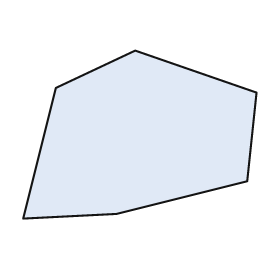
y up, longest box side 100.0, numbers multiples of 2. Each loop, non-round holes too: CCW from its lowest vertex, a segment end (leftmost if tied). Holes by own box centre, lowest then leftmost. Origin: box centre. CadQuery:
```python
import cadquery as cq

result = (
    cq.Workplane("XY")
    .moveTo(-50.0, -36.0)
    .lineTo(-10.0, -34.0)
    .lineTo(46.0, -20.0)
    .lineTo(50.0, 18.0)
    .lineTo(-2.0, 36.0)
    .lineTo(-36.0, 20.0)
    .close()
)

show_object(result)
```